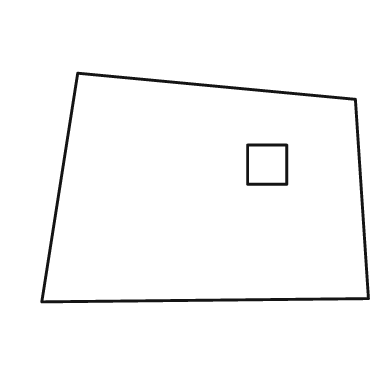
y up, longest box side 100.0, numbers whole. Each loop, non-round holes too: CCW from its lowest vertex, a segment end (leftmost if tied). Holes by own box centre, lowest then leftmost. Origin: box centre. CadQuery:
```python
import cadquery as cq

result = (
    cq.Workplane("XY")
    .moveTo(-50.0, -35.0)
    .lineTo(50.0, -34.0)
    .lineTo(46.0, 27.0)
    .lineTo(-39.0, 35.0)
    .close()
    .moveTo(13.0, 1.0)
    .lineTo(25.0, 1.0)
    .lineTo(25.0, 13.0)
    .lineTo(13.0, 13.0)
    .close()
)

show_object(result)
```